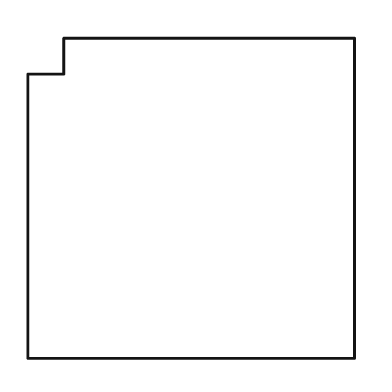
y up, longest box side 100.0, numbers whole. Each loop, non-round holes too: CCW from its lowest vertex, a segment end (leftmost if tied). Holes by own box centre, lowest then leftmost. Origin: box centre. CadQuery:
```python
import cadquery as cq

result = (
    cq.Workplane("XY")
    .moveTo(-50.0, -49.0)
    .lineTo(50.0, -49.0)
    .lineTo(50.0, 49.0)
    .lineTo(-39.0, 49.0)
    .lineTo(-39.0, 38.0)
    .lineTo(-50.0, 38.0)
    .close()
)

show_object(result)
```